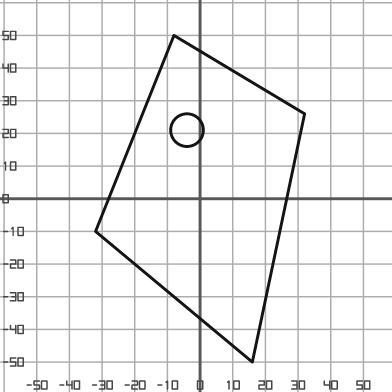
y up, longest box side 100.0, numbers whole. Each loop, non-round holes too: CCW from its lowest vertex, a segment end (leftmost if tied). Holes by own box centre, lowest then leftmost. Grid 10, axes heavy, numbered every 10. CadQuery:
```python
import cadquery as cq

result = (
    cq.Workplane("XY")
    .moveTo(16.0, -50.0)
    .lineTo(32.0, 26.0)
    .lineTo(-8.0, 50.0)
    .lineTo(-32.0, -10.0)
    .close()
    .moveTo(-4.0, 21.0)
    .circle(5.0)
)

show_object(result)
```